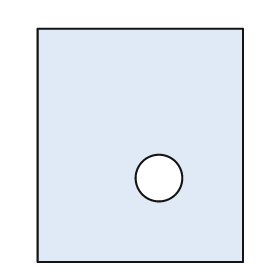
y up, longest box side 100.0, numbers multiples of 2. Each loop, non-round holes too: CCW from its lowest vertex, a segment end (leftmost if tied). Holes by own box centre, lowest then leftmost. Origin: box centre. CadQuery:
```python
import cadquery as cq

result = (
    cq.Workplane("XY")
    .moveTo(-44.0, -50.0)
    .lineTo(44.0, -50.0)
    .lineTo(44.0, 50.0)
    .lineTo(-44.0, 50.0)
    .close()
    .moveTo(8.0, -14.0)
    .circle(10.0)
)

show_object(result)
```